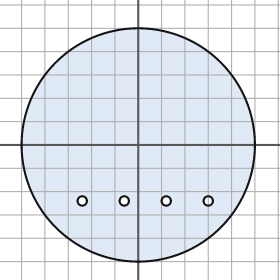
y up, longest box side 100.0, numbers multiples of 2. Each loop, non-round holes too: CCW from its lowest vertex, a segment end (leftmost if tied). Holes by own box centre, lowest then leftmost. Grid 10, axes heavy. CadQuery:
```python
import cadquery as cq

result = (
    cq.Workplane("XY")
    .moveTo(0.0, 0.0)
    .circle(50.0)
    .moveTo(-24.0, -24.0)
    .circle(2.0)
    .moveTo(-6.0, -24.0)
    .circle(2.0)
    .moveTo(12.0, -24.0)
    .circle(2.0)
    .moveTo(30.0, -24.0)
    .circle(2.0)
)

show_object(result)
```